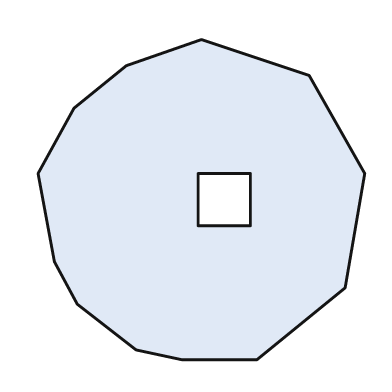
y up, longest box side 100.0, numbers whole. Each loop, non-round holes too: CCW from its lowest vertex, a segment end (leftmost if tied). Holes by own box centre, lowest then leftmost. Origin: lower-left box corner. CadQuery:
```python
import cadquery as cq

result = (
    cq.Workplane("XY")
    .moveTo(44.0, 0.0)
    .lineTo(67.0, 0.0)
    .lineTo(94.0, 22.0)
    .lineTo(100.0, 57.0)
    .lineTo(83.0, 87.0)
    .lineTo(50.0, 98.0)
    .lineTo(27.0, 90.0)
    .lineTo(11.0, 77.0)
    .lineTo(0.0, 57.0)
    .lineTo(5.0, 30.0)
    .lineTo(12.0, 17.0)
    .lineTo(30.0, 3.0)
    .close()
    .moveTo(49.0, 41.0)
    .lineTo(65.0, 41.0)
    .lineTo(65.0, 57.0)
    .lineTo(49.0, 57.0)
    .close()
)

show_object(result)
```